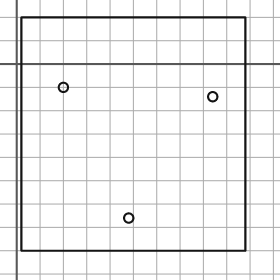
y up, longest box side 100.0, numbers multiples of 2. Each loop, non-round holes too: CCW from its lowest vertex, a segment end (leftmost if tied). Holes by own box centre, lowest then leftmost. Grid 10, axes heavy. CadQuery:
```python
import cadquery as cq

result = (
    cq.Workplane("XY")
    .moveTo(2.0, -80.0)
    .lineTo(98.0, -80.0)
    .lineTo(98.0, 20.0)
    .lineTo(2.0, 20.0)
    .close()
    .moveTo(48.0, -66.0)
    .circle(2.0)
    .moveTo(84.0, -14.0)
    .circle(2.0)
    .moveTo(20.0, -10.0)
    .circle(2.0)
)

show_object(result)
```